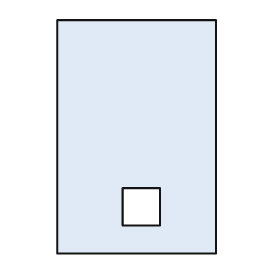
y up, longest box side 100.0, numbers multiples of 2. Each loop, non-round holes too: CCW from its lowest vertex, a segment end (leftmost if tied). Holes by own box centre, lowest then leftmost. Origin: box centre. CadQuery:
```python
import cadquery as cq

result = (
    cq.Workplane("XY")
    .moveTo(-34.0, -50.0)
    .lineTo(34.0, -50.0)
    .lineTo(34.0, 50.0)
    .lineTo(-34.0, 50.0)
    .close()
    .moveTo(-6.0, -38.0)
    .lineTo(10.0, -38.0)
    .lineTo(10.0, -22.0)
    .lineTo(-6.0, -22.0)
    .close()
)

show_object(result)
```